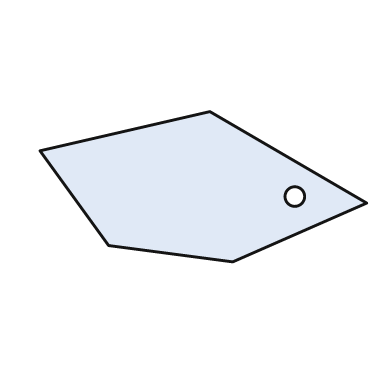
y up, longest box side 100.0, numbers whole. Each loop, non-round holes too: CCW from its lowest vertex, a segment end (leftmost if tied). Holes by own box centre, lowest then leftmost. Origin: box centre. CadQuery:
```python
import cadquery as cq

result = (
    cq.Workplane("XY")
    .moveTo(9.0, -23.0)
    .lineTo(50.0, -5.0)
    .lineTo(2.0, 23.0)
    .lineTo(-50.0, 11.0)
    .lineTo(-29.0, -18.0)
    .close()
    .moveTo(28.0, -3.0)
    .circle(3.0)
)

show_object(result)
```